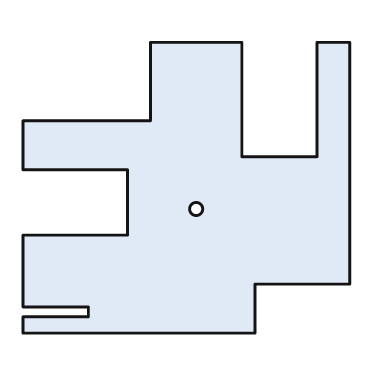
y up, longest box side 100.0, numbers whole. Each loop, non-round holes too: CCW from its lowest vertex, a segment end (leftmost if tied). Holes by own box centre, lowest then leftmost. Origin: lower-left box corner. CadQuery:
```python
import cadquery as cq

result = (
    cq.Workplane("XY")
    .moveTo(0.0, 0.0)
    .lineTo(71.0, 0.0)
    .lineTo(71.0, 15.0)
    .lineTo(100.0, 15.0)
    .lineTo(100.0, 89.0)
    .lineTo(90.0, 89.0)
    .lineTo(90.0, 54.0)
    .lineTo(67.0, 54.0)
    .lineTo(67.0, 89.0)
    .lineTo(39.0, 89.0)
    .lineTo(39.0, 65.0)
    .lineTo(0.0, 65.0)
    .lineTo(0.0, 50.0)
    .lineTo(32.0, 50.0)
    .lineTo(32.0, 30.0)
    .lineTo(0.0, 30.0)
    .lineTo(0.0, 8.0)
    .lineTo(20.0, 8.0)
    .lineTo(20.0, 5.0)
    .lineTo(0.0, 5.0)
    .close()
    .moveTo(53.0, 38.0)
    .circle(2.0)
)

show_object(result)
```